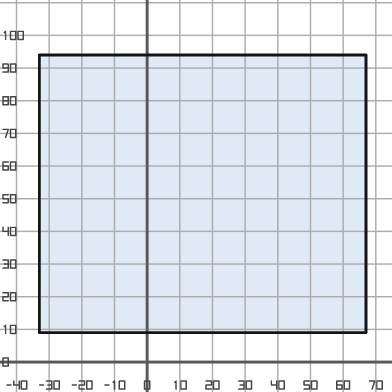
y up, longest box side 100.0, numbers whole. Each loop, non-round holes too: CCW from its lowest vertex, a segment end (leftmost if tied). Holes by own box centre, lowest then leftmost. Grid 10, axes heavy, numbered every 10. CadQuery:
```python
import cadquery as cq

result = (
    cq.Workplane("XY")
    .moveTo(-33.0, 9.0)
    .lineTo(67.0, 9.0)
    .lineTo(67.0, 94.0)
    .lineTo(-33.0, 94.0)
    .close()
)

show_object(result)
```